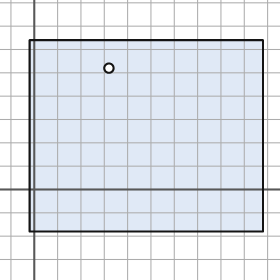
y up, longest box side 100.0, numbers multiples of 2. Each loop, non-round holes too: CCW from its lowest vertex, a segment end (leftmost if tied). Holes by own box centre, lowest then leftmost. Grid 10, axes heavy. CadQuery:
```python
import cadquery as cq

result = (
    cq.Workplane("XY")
    .moveTo(-2.0, -18.0)
    .lineTo(98.0, -18.0)
    .lineTo(98.0, 64.0)
    .lineTo(-2.0, 64.0)
    .close()
    .moveTo(32.0, 52.0)
    .circle(2.0)
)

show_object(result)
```